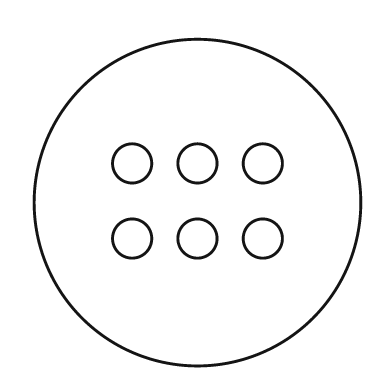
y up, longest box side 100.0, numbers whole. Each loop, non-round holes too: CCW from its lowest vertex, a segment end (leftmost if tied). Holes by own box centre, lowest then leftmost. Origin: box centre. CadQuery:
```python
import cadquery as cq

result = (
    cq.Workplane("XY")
    .moveTo(0.0, 0.0)
    .circle(50.0)
    .moveTo(-20.0, -11.0)
    .circle(6.0)
    .moveTo(0.0, -11.0)
    .circle(6.0)
    .moveTo(20.0, -11.0)
    .circle(6.0)
    .moveTo(-20.0, 12.0)
    .circle(6.0)
    .moveTo(0.0, 12.0)
    .circle(6.0)
    .moveTo(20.0, 12.0)
    .circle(6.0)
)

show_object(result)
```